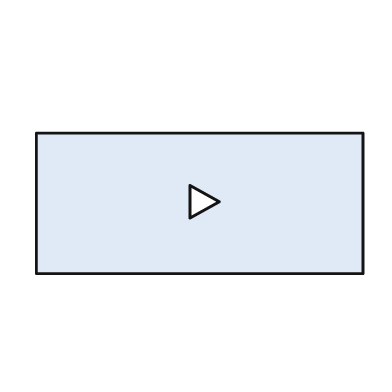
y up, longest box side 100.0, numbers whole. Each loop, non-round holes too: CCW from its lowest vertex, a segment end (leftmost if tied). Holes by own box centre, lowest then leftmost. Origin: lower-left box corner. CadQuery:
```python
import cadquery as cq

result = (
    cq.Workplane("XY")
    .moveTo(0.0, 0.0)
    .lineTo(100.0, 0.0)
    .lineTo(100.0, 43.0)
    .lineTo(0.0, 43.0)
    .close()
    .moveTo(47.0, 17.0)
    .lineTo(56.0, 22.0)
    .lineTo(47.0, 27.0)
    .close()
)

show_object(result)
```